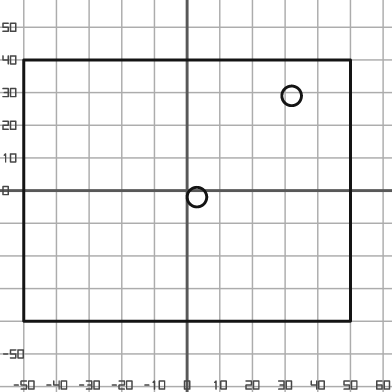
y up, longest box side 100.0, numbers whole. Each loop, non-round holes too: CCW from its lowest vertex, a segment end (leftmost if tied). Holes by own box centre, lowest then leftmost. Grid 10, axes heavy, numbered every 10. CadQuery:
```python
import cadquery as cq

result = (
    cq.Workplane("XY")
    .moveTo(-50.0, -40.0)
    .lineTo(50.0, -40.0)
    .lineTo(50.0, 40.0)
    .lineTo(-50.0, 40.0)
    .close()
    .moveTo(3.0, -2.0)
    .circle(3.0)
    .moveTo(32.0, 29.0)
    .circle(3.0)
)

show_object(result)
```